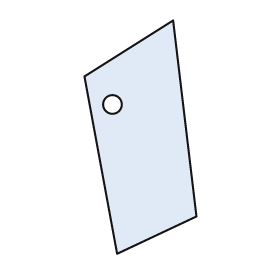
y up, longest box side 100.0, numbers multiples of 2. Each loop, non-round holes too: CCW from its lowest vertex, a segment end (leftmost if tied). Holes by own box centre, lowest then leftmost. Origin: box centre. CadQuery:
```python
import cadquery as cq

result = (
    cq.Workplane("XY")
    .moveTo(-10.0, -50.0)
    .lineTo(24.0, -34.0)
    .lineTo(14.0, 50.0)
    .lineTo(-24.0, 26.0)
    .close()
    .moveTo(-12.0, 14.0)
    .circle(4.0)
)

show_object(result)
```